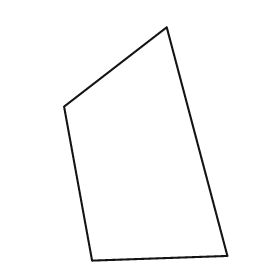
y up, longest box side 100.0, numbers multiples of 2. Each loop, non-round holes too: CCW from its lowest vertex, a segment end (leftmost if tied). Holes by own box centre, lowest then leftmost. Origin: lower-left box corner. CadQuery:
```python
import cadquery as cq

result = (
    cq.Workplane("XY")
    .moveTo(12.0, 0.0)
    .lineTo(70.0, 2.0)
    .lineTo(44.0, 100.0)
    .lineTo(0.0, 66.0)
    .close()
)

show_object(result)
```